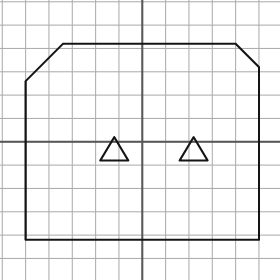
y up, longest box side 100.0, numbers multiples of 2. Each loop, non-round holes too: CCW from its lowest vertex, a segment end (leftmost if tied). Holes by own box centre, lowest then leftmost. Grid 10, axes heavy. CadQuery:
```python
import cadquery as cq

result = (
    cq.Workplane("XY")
    .moveTo(-50.0, -42.0)
    .lineTo(50.0, -42.0)
    .lineTo(50.0, 32.0)
    .lineTo(40.0, 42.0)
    .lineTo(-34.0, 42.0)
    .lineTo(-50.0, 26.0)
    .close()
    .moveTo(-18.0, -8.0)
    .lineTo(-6.0, -8.0)
    .lineTo(-12.0, 2.0)
    .close()
    .moveTo(16.0, -8.0)
    .lineTo(28.0, -8.0)
    .lineTo(22.0, 2.0)
    .close()
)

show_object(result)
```